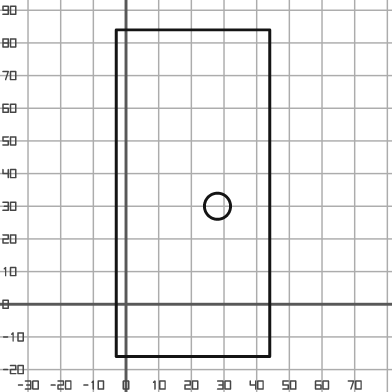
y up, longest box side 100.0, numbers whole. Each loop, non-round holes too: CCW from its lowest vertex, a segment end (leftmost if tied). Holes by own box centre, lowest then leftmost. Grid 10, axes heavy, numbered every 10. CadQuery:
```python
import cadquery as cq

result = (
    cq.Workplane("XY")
    .moveTo(-3.0, -16.0)
    .lineTo(44.0, -16.0)
    .lineTo(44.0, 84.0)
    .lineTo(-3.0, 84.0)
    .close()
    .moveTo(28.0, 30.0)
    .circle(4.0)
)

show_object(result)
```